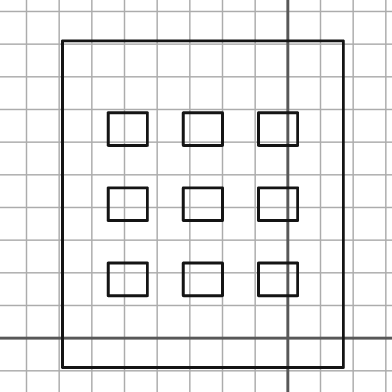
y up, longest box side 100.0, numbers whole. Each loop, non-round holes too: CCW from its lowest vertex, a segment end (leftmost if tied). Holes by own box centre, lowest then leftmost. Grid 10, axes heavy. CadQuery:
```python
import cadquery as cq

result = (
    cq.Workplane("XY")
    .moveTo(-69.0, -9.0)
    .lineTo(17.0, -9.0)
    .lineTo(17.0, 91.0)
    .lineTo(-69.0, 91.0)
    .close()
    .moveTo(-55.0, 13.0)
    .lineTo(-43.0, 13.0)
    .lineTo(-43.0, 23.0)
    .lineTo(-55.0, 23.0)
    .close()
    .moveTo(-32.0, 13.0)
    .lineTo(-20.0, 13.0)
    .lineTo(-20.0, 23.0)
    .lineTo(-32.0, 23.0)
    .close()
    .moveTo(-9.0, 13.0)
    .lineTo(3.0, 13.0)
    .lineTo(3.0, 23.0)
    .lineTo(-9.0, 23.0)
    .close()
    .moveTo(-55.0, 36.0)
    .lineTo(-43.0, 36.0)
    .lineTo(-43.0, 46.0)
    .lineTo(-55.0, 46.0)
    .close()
    .moveTo(-32.0, 36.0)
    .lineTo(-20.0, 36.0)
    .lineTo(-20.0, 46.0)
    .lineTo(-32.0, 46.0)
    .close()
    .moveTo(-9.0, 36.0)
    .lineTo(3.0, 36.0)
    .lineTo(3.0, 46.0)
    .lineTo(-9.0, 46.0)
    .close()
    .moveTo(-55.0, 59.0)
    .lineTo(-43.0, 59.0)
    .lineTo(-43.0, 69.0)
    .lineTo(-55.0, 69.0)
    .close()
    .moveTo(-32.0, 59.0)
    .lineTo(-20.0, 59.0)
    .lineTo(-20.0, 69.0)
    .lineTo(-32.0, 69.0)
    .close()
    .moveTo(-9.0, 59.0)
    .lineTo(3.0, 59.0)
    .lineTo(3.0, 69.0)
    .lineTo(-9.0, 69.0)
    .close()
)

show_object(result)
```